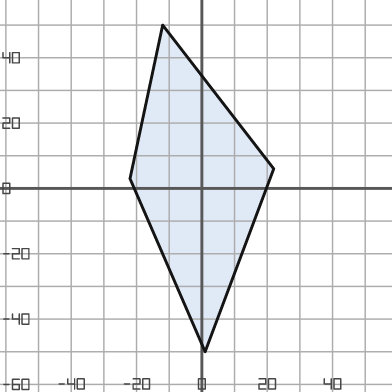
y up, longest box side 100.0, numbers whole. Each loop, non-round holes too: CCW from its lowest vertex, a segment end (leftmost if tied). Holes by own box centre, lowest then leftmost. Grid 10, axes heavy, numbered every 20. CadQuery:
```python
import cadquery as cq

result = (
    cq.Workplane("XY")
    .moveTo(1.0, -50.0)
    .lineTo(22.0, 6.0)
    .lineTo(-12.0, 50.0)
    .lineTo(-22.0, 3.0)
    .close()
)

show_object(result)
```